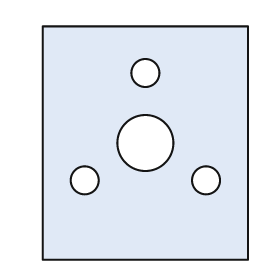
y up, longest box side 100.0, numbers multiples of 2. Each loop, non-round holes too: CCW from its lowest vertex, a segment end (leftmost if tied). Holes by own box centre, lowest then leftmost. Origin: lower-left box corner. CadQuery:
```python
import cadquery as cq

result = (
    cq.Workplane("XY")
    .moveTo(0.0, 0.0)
    .lineTo(88.0, 0.0)
    .lineTo(88.0, 100.0)
    .lineTo(0.0, 100.0)
    .close()
    .moveTo(18.0, 34.0)
    .circle(6.0)
    .moveTo(70.0, 34.0)
    .circle(6.0)
    .moveTo(44.0, 50.0)
    .circle(12.0)
    .moveTo(44.0, 80.0)
    .circle(6.0)
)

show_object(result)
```